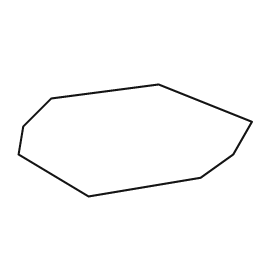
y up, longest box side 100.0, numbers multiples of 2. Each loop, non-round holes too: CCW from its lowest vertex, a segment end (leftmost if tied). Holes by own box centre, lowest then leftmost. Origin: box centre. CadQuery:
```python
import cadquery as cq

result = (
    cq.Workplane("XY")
    .moveTo(-20.0, -24.0)
    .lineTo(28.0, -16.0)
    .lineTo(42.0, -6.0)
    .lineTo(50.0, 8.0)
    .lineTo(10.0, 24.0)
    .lineTo(-36.0, 18.0)
    .lineTo(-48.0, 6.0)
    .lineTo(-50.0, -6.0)
    .close()
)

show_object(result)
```